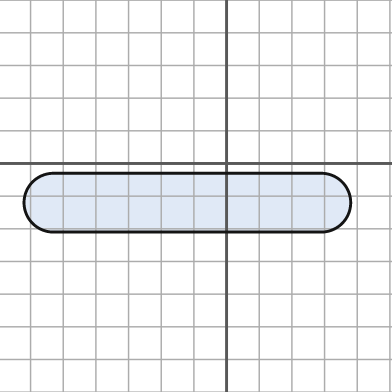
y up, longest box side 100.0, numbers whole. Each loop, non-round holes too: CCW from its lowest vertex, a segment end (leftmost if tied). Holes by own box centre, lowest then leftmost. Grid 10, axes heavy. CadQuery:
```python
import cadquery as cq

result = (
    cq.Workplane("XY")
    .moveTo(-53.0, -21.0)
    .lineTo(29.0, -21.0)
    .threePointArc((38.0, -12.0), (29.0, -3.0))
    .lineTo(-53.0, -3.0)
    .threePointArc((-62.0, -12.0), (-53.0, -21.0))
    .close()
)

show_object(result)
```